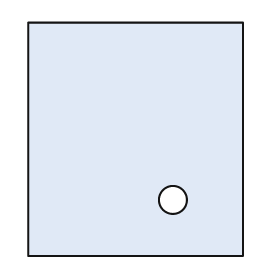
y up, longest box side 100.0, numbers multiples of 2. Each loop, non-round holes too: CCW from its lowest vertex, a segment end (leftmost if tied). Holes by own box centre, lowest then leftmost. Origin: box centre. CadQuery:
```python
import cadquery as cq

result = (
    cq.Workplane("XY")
    .moveTo(-46.0, -50.0)
    .lineTo(46.0, -50.0)
    .lineTo(46.0, 50.0)
    .lineTo(-46.0, 50.0)
    .close()
    .moveTo(16.0, -26.0)
    .circle(6.0)
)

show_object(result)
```